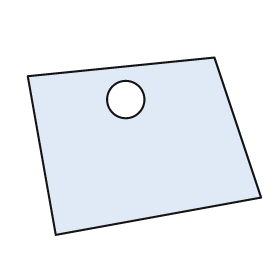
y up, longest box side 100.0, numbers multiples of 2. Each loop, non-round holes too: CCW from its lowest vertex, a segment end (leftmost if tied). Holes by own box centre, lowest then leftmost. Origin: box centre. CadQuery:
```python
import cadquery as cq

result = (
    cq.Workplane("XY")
    .moveTo(-38.0, -38.0)
    .lineTo(50.0, -22.0)
    .lineTo(30.0, 38.0)
    .lineTo(-50.0, 30.0)
    .close()
    .moveTo(-8.0, 20.0)
    .circle(8.0)
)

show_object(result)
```